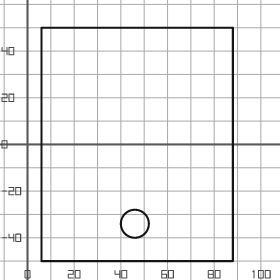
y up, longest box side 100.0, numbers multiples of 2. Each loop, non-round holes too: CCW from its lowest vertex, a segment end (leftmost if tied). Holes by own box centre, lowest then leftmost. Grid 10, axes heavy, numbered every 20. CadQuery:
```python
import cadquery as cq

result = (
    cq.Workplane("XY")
    .moveTo(6.0, -50.0)
    .lineTo(88.0, -50.0)
    .lineTo(88.0, 50.0)
    .lineTo(6.0, 50.0)
    .close()
    .moveTo(46.0, -34.0)
    .circle(6.0)
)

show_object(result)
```